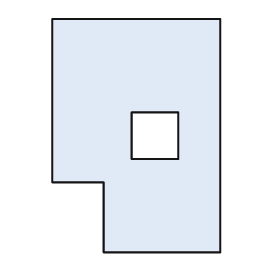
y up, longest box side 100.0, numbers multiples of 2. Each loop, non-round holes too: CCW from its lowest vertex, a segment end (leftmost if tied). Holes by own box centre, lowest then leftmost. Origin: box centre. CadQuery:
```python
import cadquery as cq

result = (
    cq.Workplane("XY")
    .moveTo(-14.0, -50.0)
    .lineTo(36.0, -50.0)
    .lineTo(36.0, 50.0)
    .lineTo(-36.0, 50.0)
    .lineTo(-36.0, -20.0)
    .lineTo(-14.0, -20.0)
    .close()
    .moveTo(-2.0, -10.0)
    .lineTo(18.0, -10.0)
    .lineTo(18.0, 10.0)
    .lineTo(-2.0, 10.0)
    .close()
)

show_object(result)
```